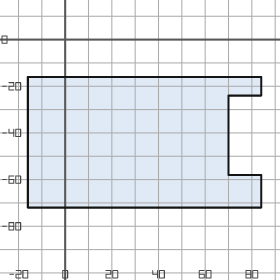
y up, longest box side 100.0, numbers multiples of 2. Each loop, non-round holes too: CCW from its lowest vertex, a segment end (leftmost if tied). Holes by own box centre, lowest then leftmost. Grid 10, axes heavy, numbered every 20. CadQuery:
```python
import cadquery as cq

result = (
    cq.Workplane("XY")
    .moveTo(-16.0, -72.0)
    .lineTo(84.0, -72.0)
    .lineTo(84.0, -58.0)
    .lineTo(70.0, -58.0)
    .lineTo(70.0, -24.0)
    .lineTo(84.0, -24.0)
    .lineTo(84.0, -16.0)
    .lineTo(-16.0, -16.0)
    .close()
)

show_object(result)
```